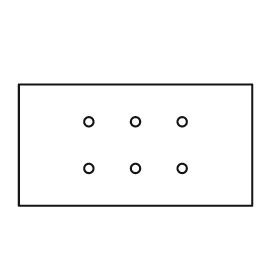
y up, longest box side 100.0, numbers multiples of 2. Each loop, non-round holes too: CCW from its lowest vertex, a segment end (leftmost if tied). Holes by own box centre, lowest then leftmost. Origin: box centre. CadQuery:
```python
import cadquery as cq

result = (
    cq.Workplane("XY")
    .moveTo(-50.0, -26.0)
    .lineTo(50.0, -26.0)
    .lineTo(50.0, 26.0)
    .lineTo(-50.0, 26.0)
    .close()
    .moveTo(-20.0, -10.0)
    .circle(2.0)
    .moveTo(0.0, -10.0)
    .circle(2.0)
    .moveTo(20.0, -10.0)
    .circle(2.0)
    .moveTo(-20.0, 10.0)
    .circle(2.0)
    .moveTo(0.0, 10.0)
    .circle(2.0)
    .moveTo(20.0, 10.0)
    .circle(2.0)
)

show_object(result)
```